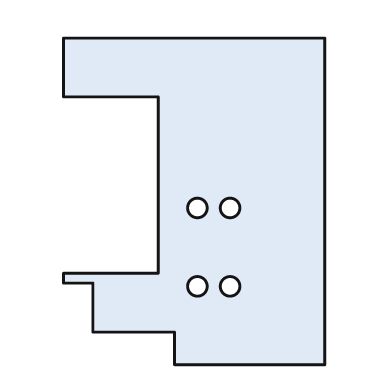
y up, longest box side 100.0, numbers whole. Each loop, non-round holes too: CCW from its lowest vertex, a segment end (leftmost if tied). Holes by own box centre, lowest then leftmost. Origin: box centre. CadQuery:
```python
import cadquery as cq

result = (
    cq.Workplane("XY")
    .moveTo(-6.0, -50.0)
    .lineTo(40.0, -50.0)
    .lineTo(40.0, 50.0)
    .lineTo(-40.0, 50.0)
    .lineTo(-40.0, 32.0)
    .lineTo(-11.0, 32.0)
    .lineTo(-11.0, -22.0)
    .lineTo(-40.0, -22.0)
    .lineTo(-40.0, -25.0)
    .lineTo(-31.0, -25.0)
    .lineTo(-31.0, -40.0)
    .lineTo(-6.0, -40.0)
    .close()
    .moveTo(1.0, -26.0)
    .circle(3.0)
    .moveTo(11.0, -26.0)
    .circle(3.0)
    .moveTo(1.0, -2.0)
    .circle(3.0)
    .moveTo(11.0, -2.0)
    .circle(3.0)
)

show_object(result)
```